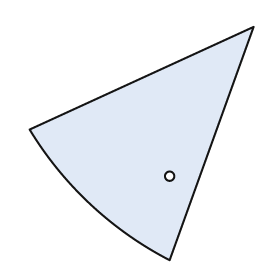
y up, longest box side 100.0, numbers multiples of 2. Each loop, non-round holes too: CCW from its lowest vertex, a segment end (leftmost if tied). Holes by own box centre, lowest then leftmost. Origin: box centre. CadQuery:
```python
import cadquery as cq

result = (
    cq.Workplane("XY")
    .moveTo(12.0, -50.0)
    .lineTo(48.0, 50.0)
    .lineTo(-48.0, 6.0)
    .threePointArc((-22.0, -26.0), (12.0, -50.0))
    .close()
    .moveTo(12.0, -14.0)
    .circle(2.0)
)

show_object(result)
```